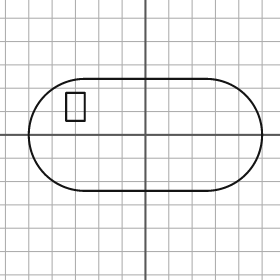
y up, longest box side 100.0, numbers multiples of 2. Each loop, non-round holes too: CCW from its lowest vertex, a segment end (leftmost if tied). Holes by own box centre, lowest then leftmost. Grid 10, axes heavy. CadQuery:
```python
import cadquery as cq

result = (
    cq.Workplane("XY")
    .moveTo(-26.0, -24.0)
    .lineTo(26.0, -24.0)
    .threePointArc((50.0, 0.0), (26.0, 24.0))
    .lineTo(-26.0, 24.0)
    .threePointArc((-50.0, 0.0), (-26.0, -24.0))
    .close()
    .moveTo(-34.0, 6.0)
    .lineTo(-26.0, 6.0)
    .lineTo(-26.0, 18.0)
    .lineTo(-34.0, 18.0)
    .close()
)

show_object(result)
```